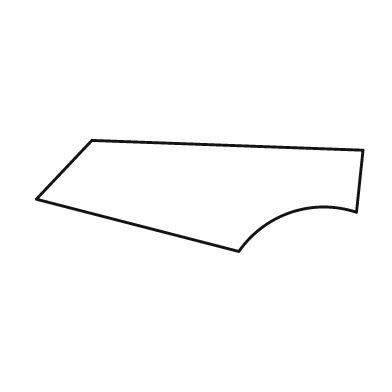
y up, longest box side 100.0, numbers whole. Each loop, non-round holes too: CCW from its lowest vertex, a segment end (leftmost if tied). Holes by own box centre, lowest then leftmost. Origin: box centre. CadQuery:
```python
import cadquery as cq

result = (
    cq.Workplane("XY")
    .moveTo(12.0, -17.0)
    .threePointArc((28.0, -5.0), (48.0, -5.0))
    .lineTo(50.0, 14.0)
    .lineTo(-33.0, 17.0)
    .lineTo(-50.0, -1.0)
    .close()
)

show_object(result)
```